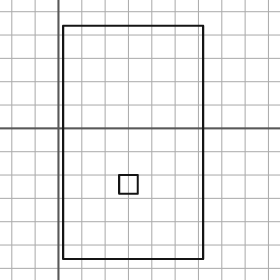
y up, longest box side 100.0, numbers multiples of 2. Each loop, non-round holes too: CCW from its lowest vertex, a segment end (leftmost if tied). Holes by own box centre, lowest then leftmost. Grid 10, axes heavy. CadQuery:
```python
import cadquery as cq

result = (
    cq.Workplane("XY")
    .moveTo(2.0, -56.0)
    .lineTo(62.0, -56.0)
    .lineTo(62.0, 44.0)
    .lineTo(2.0, 44.0)
    .close()
    .moveTo(26.0, -28.0)
    .lineTo(34.0, -28.0)
    .lineTo(34.0, -20.0)
    .lineTo(26.0, -20.0)
    .close()
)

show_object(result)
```